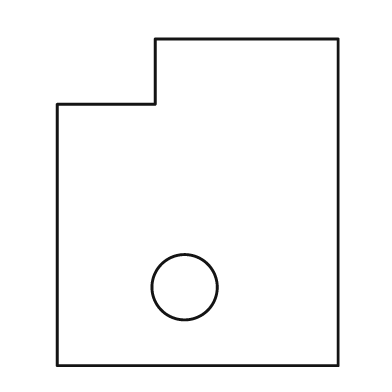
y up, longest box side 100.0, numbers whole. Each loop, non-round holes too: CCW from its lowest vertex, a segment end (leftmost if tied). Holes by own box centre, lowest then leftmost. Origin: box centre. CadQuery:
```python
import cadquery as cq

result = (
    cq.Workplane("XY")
    .moveTo(-43.0, -50.0)
    .lineTo(43.0, -50.0)
    .lineTo(43.0, 50.0)
    .lineTo(-13.0, 50.0)
    .lineTo(-13.0, 30.0)
    .lineTo(-43.0, 30.0)
    .close()
    .moveTo(-4.0, -26.0)
    .circle(10.0)
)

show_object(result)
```